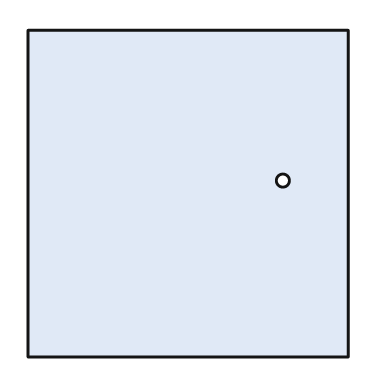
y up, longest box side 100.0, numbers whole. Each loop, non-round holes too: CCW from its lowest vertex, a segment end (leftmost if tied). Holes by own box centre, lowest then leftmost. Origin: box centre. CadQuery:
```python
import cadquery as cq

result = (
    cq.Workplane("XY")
    .moveTo(-49.0, -50.0)
    .lineTo(49.0, -50.0)
    .lineTo(49.0, 50.0)
    .lineTo(-49.0, 50.0)
    .close()
    .moveTo(29.0, 4.0)
    .circle(2.0)
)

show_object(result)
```